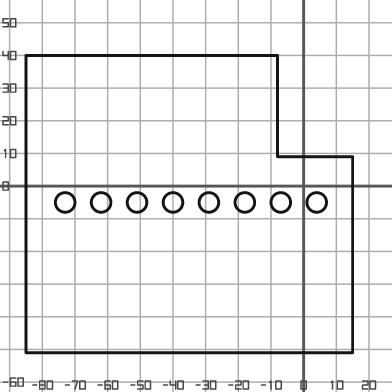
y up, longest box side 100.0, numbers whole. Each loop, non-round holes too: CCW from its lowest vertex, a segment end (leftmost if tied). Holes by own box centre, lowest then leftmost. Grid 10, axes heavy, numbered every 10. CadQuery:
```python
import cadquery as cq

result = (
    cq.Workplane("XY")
    .moveTo(-85.0, -51.0)
    .lineTo(15.0, -51.0)
    .lineTo(15.0, 9.0)
    .lineTo(-8.0, 9.0)
    .lineTo(-8.0, 40.0)
    .lineTo(-85.0, 40.0)
    .close()
    .moveTo(-73.0, -5.0)
    .circle(3.0)
    .moveTo(-62.0, -5.0)
    .circle(3.0)
    .moveTo(-51.0, -5.0)
    .circle(3.0)
    .moveTo(-40.0, -5.0)
    .circle(3.0)
    .moveTo(-29.0, -5.0)
    .circle(3.0)
    .moveTo(-18.0, -5.0)
    .circle(3.0)
    .moveTo(-7.0, -5.0)
    .circle(3.0)
    .moveTo(4.0, -5.0)
    .circle(3.0)
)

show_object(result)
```